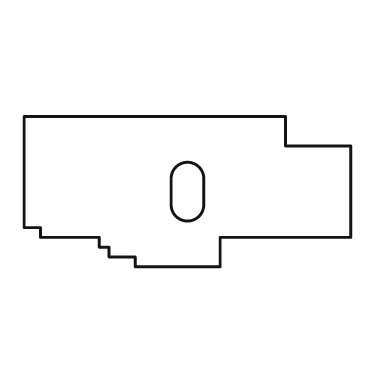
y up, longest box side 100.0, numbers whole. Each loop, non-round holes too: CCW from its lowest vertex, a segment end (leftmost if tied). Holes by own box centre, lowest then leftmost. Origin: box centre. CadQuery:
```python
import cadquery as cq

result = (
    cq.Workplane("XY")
    .moveTo(-16.0, -23.0)
    .lineTo(10.0, -23.0)
    .lineTo(10.0, -14.0)
    .lineTo(50.0, -14.0)
    .lineTo(50.0, 14.0)
    .lineTo(30.0, 14.0)
    .lineTo(30.0, 23.0)
    .lineTo(-50.0, 23.0)
    .lineTo(-50.0, -11.0)
    .lineTo(-45.0, -11.0)
    .lineTo(-45.0, -14.0)
    .lineTo(-27.0, -14.0)
    .lineTo(-27.0, -17.0)
    .lineTo(-24.0, -17.0)
    .lineTo(-24.0, -20.0)
    .lineTo(-16.0, -20.0)
    .close()
    .moveTo(-5.0, -4.0)
    .threePointArc((0.0, -9.0), (5.0, -4.0))
    .lineTo(5.0, 4.0)
    .threePointArc((0.0, 9.0), (-5.0, 4.0))
    .close()
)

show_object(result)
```